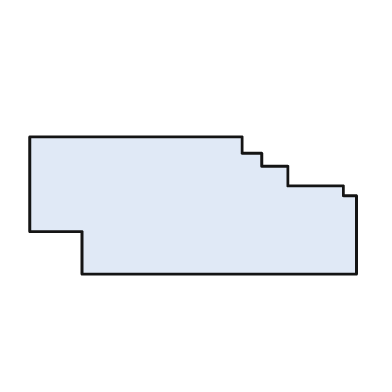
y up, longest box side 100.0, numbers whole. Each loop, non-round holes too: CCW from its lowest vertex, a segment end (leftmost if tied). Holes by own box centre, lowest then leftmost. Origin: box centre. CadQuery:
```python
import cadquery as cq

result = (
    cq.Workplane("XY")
    .moveTo(-34.0, -21.0)
    .lineTo(50.0, -21.0)
    .lineTo(50.0, 3.0)
    .lineTo(46.0, 3.0)
    .lineTo(46.0, 6.0)
    .lineTo(29.0, 6.0)
    .lineTo(29.0, 12.0)
    .lineTo(21.0, 12.0)
    .lineTo(21.0, 16.0)
    .lineTo(15.0, 16.0)
    .lineTo(15.0, 21.0)
    .lineTo(-50.0, 21.0)
    .lineTo(-50.0, -8.0)
    .lineTo(-34.0, -8.0)
    .close()
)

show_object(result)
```